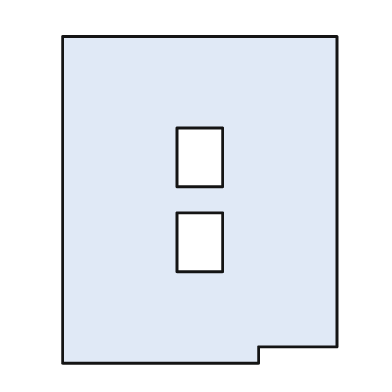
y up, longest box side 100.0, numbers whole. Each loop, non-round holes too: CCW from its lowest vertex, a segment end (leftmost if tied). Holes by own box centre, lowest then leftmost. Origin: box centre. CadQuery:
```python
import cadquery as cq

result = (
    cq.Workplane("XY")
    .moveTo(-42.0, -50.0)
    .lineTo(18.0, -50.0)
    .lineTo(18.0, -45.0)
    .lineTo(42.0, -45.0)
    .lineTo(42.0, 50.0)
    .lineTo(-42.0, 50.0)
    .close()
    .moveTo(-7.0, -22.0)
    .lineTo(7.0, -22.0)
    .lineTo(7.0, -4.0)
    .lineTo(-7.0, -4.0)
    .close()
    .moveTo(-7.0, 4.0)
    .lineTo(7.0, 4.0)
    .lineTo(7.0, 22.0)
    .lineTo(-7.0, 22.0)
    .close()
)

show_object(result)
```